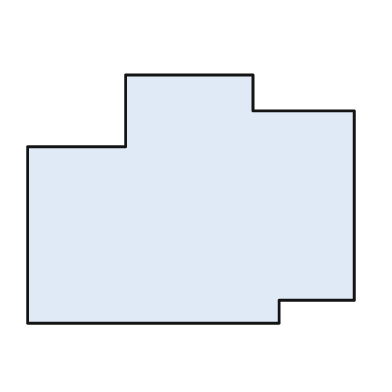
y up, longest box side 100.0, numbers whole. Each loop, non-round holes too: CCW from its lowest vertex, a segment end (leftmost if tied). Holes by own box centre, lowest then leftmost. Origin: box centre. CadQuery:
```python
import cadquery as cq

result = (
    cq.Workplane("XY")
    .moveTo(-50.0, -38.0)
    .lineTo(27.0, -38.0)
    .lineTo(27.0, -31.0)
    .lineTo(50.0, -31.0)
    .lineTo(50.0, 27.0)
    .lineTo(19.0, 27.0)
    .lineTo(19.0, 38.0)
    .lineTo(-20.0, 38.0)
    .lineTo(-20.0, 16.0)
    .lineTo(-50.0, 16.0)
    .close()
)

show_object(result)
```